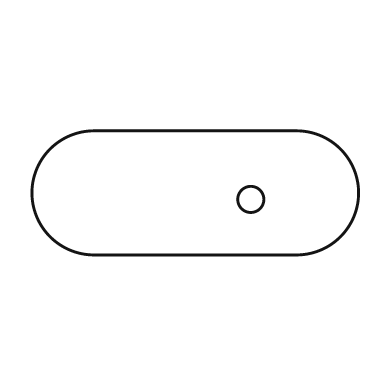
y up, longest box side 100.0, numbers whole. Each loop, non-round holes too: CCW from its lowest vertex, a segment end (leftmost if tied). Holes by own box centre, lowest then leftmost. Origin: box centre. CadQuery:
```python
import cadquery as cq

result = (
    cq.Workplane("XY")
    .moveTo(-31.0, -19.0)
    .lineTo(31.0, -19.0)
    .threePointArc((50.0, 0.0), (31.0, 19.0))
    .lineTo(-31.0, 19.0)
    .threePointArc((-50.0, 0.0), (-31.0, -19.0))
    .close()
    .moveTo(17.0, -2.0)
    .circle(4.0)
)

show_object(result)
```